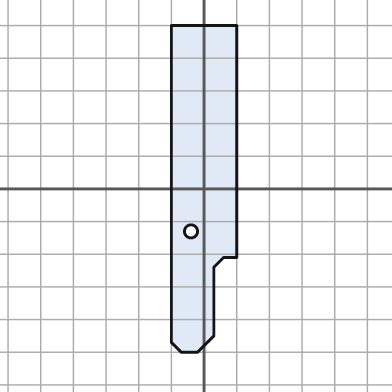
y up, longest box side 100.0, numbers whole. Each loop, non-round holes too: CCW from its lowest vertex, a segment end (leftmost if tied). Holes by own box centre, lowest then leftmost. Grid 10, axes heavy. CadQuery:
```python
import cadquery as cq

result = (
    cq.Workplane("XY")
    .moveTo(-7.0, -50.0)
    .lineTo(-2.0, -50.0)
    .lineTo(3.0, -45.0)
    .lineTo(3.0, -24.0)
    .lineTo(6.0, -21.0)
    .lineTo(10.0, -21.0)
    .lineTo(10.0, 50.0)
    .lineTo(-10.0, 50.0)
    .lineTo(-10.0, -47.0)
    .close()
    .moveTo(-4.0, -13.0)
    .circle(2.0)
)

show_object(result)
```